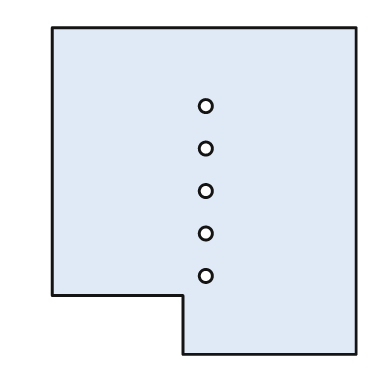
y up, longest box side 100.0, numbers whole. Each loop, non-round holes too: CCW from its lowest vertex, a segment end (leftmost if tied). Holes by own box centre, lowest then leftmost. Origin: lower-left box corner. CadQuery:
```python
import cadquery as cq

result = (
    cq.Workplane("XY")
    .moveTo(40.0, 0.0)
    .lineTo(93.0, 0.0)
    .lineTo(93.0, 100.0)
    .lineTo(0.0, 100.0)
    .lineTo(0.0, 18.0)
    .lineTo(40.0, 18.0)
    .close()
    .moveTo(47.0, 24.0)
    .circle(2.0)
    .moveTo(47.0, 37.0)
    .circle(2.0)
    .moveTo(47.0, 50.0)
    .circle(2.0)
    .moveTo(47.0, 63.0)
    .circle(2.0)
    .moveTo(47.0, 76.0)
    .circle(2.0)
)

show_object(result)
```